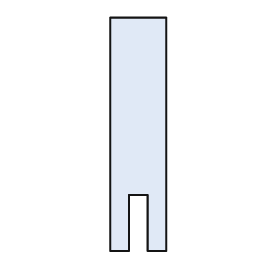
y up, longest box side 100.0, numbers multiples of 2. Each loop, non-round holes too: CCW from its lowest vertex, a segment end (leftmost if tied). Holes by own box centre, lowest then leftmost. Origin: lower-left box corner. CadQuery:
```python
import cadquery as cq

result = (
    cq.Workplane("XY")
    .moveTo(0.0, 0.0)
    .lineTo(8.0, 0.0)
    .lineTo(8.0, 24.0)
    .lineTo(16.0, 24.0)
    .lineTo(16.0, 0.0)
    .lineTo(24.0, 0.0)
    .lineTo(24.0, 100.0)
    .lineTo(0.0, 100.0)
    .close()
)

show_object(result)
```